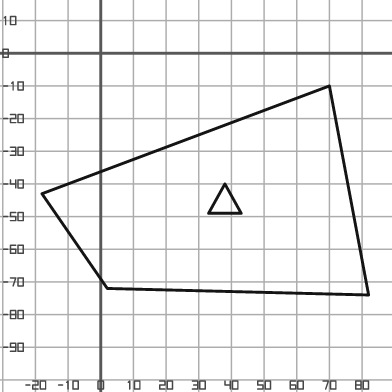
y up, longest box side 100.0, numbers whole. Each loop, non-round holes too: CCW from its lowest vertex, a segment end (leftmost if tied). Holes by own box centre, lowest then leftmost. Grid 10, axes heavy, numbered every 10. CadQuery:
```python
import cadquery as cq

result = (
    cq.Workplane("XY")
    .moveTo(82.0, -74.0)
    .lineTo(70.0, -10.0)
    .lineTo(-18.0, -43.0)
    .lineTo(2.0, -72.0)
    .close()
    .moveTo(33.0, -49.0)
    .lineTo(43.0, -49.0)
    .lineTo(38.0, -40.0)
    .close()
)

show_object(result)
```